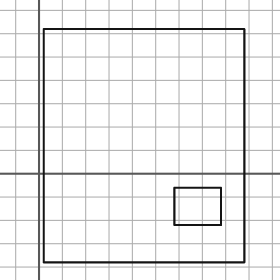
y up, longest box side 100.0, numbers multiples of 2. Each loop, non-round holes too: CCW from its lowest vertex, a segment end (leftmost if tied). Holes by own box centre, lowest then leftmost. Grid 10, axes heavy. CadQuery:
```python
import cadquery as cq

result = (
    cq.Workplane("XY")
    .moveTo(2.0, -38.0)
    .lineTo(88.0, -38.0)
    .lineTo(88.0, 62.0)
    .lineTo(2.0, 62.0)
    .close()
    .moveTo(58.0, -22.0)
    .lineTo(78.0, -22.0)
    .lineTo(78.0, -6.0)
    .lineTo(58.0, -6.0)
    .close()
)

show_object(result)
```